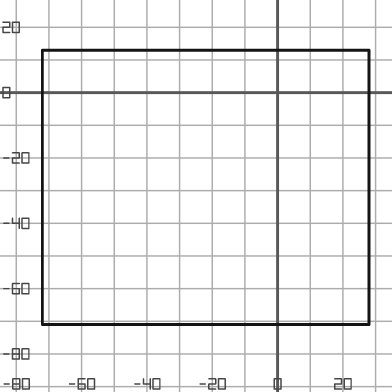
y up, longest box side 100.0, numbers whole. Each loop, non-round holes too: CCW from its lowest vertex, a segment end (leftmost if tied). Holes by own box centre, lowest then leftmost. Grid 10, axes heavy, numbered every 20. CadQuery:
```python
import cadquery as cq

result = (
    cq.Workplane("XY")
    .moveTo(-72.0, -71.0)
    .lineTo(28.0, -71.0)
    .lineTo(28.0, 13.0)
    .lineTo(-72.0, 13.0)
    .close()
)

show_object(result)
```